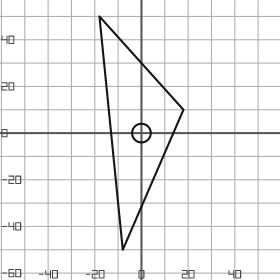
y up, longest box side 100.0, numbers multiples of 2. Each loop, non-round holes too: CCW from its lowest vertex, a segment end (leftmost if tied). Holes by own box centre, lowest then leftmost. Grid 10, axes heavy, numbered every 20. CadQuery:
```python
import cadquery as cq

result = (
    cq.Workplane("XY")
    .moveTo(-8.0, -50.0)
    .lineTo(18.0, 10.0)
    .lineTo(-18.0, 50.0)
    .close()
    .moveTo(0.0, 0.0)
    .circle(4.0)
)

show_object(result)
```